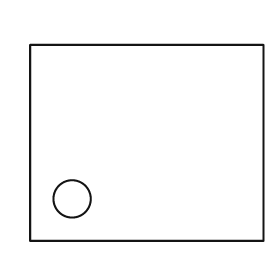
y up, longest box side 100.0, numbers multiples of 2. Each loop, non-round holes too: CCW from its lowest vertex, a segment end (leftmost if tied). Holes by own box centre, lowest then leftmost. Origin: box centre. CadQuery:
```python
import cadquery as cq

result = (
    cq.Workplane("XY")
    .moveTo(-50.0, -42.0)
    .lineTo(50.0, -42.0)
    .lineTo(50.0, 42.0)
    .lineTo(-50.0, 42.0)
    .close()
    .moveTo(-32.0, -24.0)
    .circle(8.0)
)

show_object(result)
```